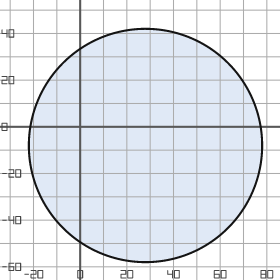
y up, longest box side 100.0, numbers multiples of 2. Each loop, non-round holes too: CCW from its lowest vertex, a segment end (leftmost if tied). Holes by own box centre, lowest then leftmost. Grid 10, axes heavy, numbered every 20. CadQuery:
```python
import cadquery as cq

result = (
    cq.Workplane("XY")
    .moveTo(28.0, -8.0)
    .circle(50.0)
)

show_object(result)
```